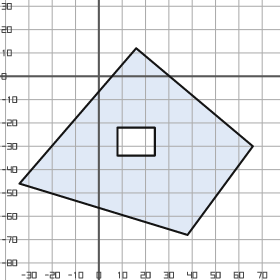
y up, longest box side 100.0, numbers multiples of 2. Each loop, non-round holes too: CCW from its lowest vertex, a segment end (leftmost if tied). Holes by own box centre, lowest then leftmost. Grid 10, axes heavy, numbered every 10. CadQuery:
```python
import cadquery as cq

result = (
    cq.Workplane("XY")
    .moveTo(38.0, -68.0)
    .lineTo(66.0, -30.0)
    .lineTo(16.0, 12.0)
    .lineTo(-34.0, -46.0)
    .close()
    .moveTo(8.0, -34.0)
    .lineTo(24.0, -34.0)
    .lineTo(24.0, -22.0)
    .lineTo(8.0, -22.0)
    .close()
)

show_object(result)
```